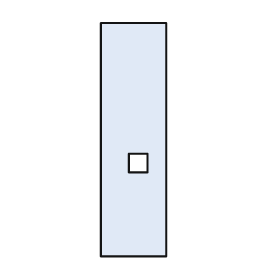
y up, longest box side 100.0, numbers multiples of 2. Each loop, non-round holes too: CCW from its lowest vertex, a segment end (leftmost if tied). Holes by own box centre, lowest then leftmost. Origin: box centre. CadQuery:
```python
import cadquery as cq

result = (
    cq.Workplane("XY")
    .moveTo(-14.0, -50.0)
    .lineTo(14.0, -50.0)
    .lineTo(14.0, 50.0)
    .lineTo(-14.0, 50.0)
    .close()
    .moveTo(-2.0, -14.0)
    .lineTo(6.0, -14.0)
    .lineTo(6.0, -6.0)
    .lineTo(-2.0, -6.0)
    .close()
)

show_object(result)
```